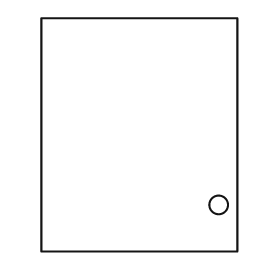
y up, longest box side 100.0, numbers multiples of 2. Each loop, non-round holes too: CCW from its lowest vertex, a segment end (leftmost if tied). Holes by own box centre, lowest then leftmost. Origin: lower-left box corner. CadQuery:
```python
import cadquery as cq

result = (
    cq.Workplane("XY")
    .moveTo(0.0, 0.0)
    .lineTo(84.0, 0.0)
    .lineTo(84.0, 100.0)
    .lineTo(0.0, 100.0)
    .close()
    .moveTo(76.0, 20.0)
    .circle(4.0)
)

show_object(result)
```